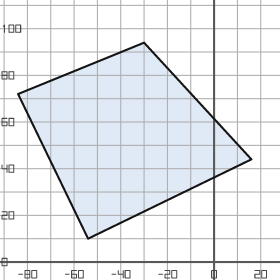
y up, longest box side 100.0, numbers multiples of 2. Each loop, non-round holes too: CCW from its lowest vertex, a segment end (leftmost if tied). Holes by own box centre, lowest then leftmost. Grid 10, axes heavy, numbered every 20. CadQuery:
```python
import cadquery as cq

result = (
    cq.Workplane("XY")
    .moveTo(-54.0, 10.0)
    .lineTo(16.0, 44.0)
    .lineTo(-30.0, 94.0)
    .lineTo(-84.0, 72.0)
    .close()
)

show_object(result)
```